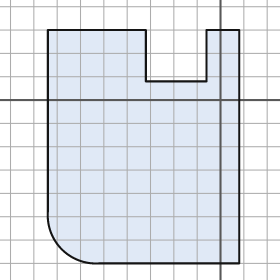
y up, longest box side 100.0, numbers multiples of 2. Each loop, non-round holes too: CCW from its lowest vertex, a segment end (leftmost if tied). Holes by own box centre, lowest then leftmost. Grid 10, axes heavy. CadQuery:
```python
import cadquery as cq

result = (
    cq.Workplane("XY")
    .moveTo(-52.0, -70.0)
    .lineTo(8.0, -70.0)
    .lineTo(8.0, 30.0)
    .lineTo(-6.0, 30.0)
    .lineTo(-6.0, 8.0)
    .lineTo(-32.0, 8.0)
    .lineTo(-32.0, 30.0)
    .lineTo(-74.0, 30.0)
    .lineTo(-74.0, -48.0)
    .threePointArc((-68.0, -64.0), (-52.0, -70.0))
    .close()
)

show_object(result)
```